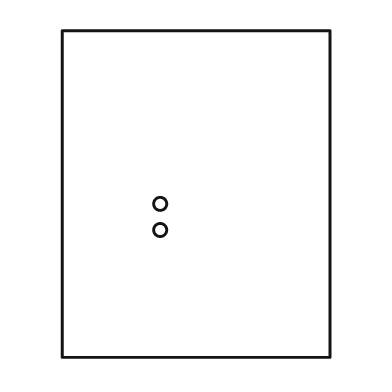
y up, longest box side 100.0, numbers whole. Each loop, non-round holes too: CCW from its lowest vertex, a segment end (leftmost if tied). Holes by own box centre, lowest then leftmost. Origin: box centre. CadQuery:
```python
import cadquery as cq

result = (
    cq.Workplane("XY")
    .moveTo(-41.0, -50.0)
    .lineTo(41.0, -50.0)
    .lineTo(41.0, 50.0)
    .lineTo(-41.0, 50.0)
    .close()
    .moveTo(-11.0, -11.0)
    .circle(2.0)
    .moveTo(-11.0, -3.0)
    .circle(2.0)
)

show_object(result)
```